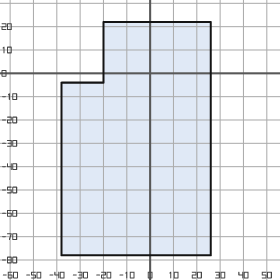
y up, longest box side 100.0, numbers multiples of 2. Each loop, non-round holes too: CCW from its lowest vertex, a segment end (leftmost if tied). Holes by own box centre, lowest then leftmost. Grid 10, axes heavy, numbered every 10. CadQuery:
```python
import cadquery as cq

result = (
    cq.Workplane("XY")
    .moveTo(-38.0, -78.0)
    .lineTo(26.0, -78.0)
    .lineTo(26.0, 22.0)
    .lineTo(-20.0, 22.0)
    .lineTo(-20.0, -4.0)
    .lineTo(-38.0, -4.0)
    .close()
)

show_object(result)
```